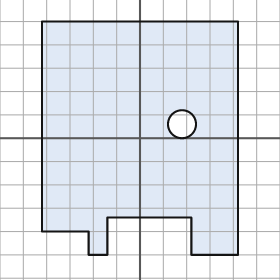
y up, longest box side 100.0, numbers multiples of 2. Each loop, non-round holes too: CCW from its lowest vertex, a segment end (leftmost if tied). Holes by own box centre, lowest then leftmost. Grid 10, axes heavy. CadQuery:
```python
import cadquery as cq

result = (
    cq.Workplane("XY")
    .moveTo(-22.0, -50.0)
    .lineTo(-14.0, -50.0)
    .lineTo(-14.0, -34.0)
    .lineTo(22.0, -34.0)
    .lineTo(22.0, -50.0)
    .lineTo(42.0, -50.0)
    .lineTo(42.0, 50.0)
    .lineTo(-42.0, 50.0)
    .lineTo(-42.0, -40.0)
    .lineTo(-22.0, -40.0)
    .close()
    .moveTo(18.0, 6.0)
    .circle(6.0)
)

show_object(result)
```